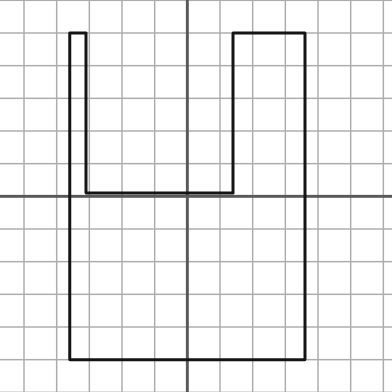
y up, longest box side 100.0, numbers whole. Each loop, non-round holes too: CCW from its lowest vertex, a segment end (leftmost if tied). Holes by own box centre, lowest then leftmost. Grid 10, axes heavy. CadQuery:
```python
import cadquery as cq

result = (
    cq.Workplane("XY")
    .moveTo(-36.0, -50.0)
    .lineTo(36.0, -50.0)
    .lineTo(36.0, 50.0)
    .lineTo(14.0, 50.0)
    .lineTo(14.0, 1.0)
    .lineTo(-31.0, 1.0)
    .lineTo(-31.0, 50.0)
    .lineTo(-36.0, 50.0)
    .close()
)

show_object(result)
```